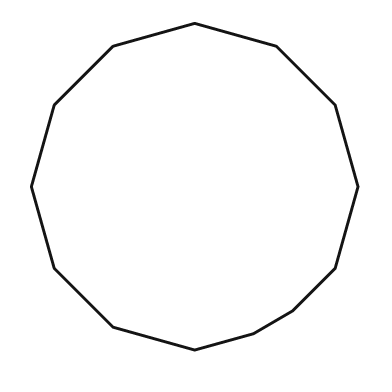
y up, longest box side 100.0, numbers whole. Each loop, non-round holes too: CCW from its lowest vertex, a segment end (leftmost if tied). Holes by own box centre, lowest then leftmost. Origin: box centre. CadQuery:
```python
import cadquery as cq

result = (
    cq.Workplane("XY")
    .moveTo(0.0, -50.0)
    .lineTo(18.0, -45.0)
    .lineTo(30.0, -38.0)
    .lineTo(43.0, -25.0)
    .lineTo(50.0, 0.0)
    .lineTo(43.0, 25.0)
    .lineTo(25.0, 43.0)
    .lineTo(0.0, 50.0)
    .lineTo(-25.0, 43.0)
    .lineTo(-43.0, 25.0)
    .lineTo(-50.0, 0.0)
    .lineTo(-43.0, -25.0)
    .lineTo(-25.0, -43.0)
    .close()
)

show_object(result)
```